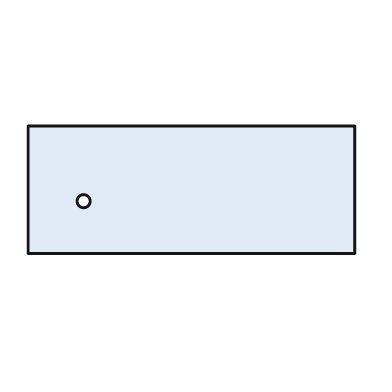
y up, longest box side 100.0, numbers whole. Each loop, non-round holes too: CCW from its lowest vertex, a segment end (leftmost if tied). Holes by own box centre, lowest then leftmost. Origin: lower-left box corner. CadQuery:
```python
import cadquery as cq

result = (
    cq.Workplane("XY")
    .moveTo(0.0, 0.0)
    .lineTo(100.0, 0.0)
    .lineTo(100.0, 39.0)
    .lineTo(0.0, 39.0)
    .close()
    .moveTo(17.0, 16.0)
    .circle(2.0)
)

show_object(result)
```